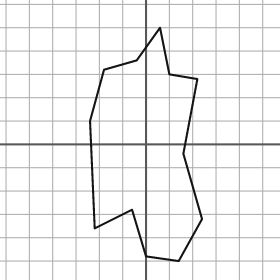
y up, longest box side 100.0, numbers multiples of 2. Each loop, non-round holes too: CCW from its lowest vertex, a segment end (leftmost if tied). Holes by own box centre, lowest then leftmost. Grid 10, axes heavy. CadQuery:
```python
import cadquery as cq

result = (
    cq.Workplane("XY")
    .moveTo(14.0, -50.0)
    .lineTo(24.0, -32.0)
    .lineTo(16.0, -4.0)
    .lineTo(22.0, 28.0)
    .lineTo(10.0, 30.0)
    .lineTo(6.0, 50.0)
    .lineTo(-4.0, 36.0)
    .lineTo(-18.0, 32.0)
    .lineTo(-24.0, 10.0)
    .lineTo(-22.0, -36.0)
    .lineTo(-6.0, -28.0)
    .lineTo(0.0, -48.0)
    .close()
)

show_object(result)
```